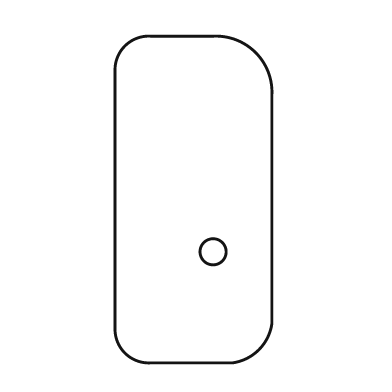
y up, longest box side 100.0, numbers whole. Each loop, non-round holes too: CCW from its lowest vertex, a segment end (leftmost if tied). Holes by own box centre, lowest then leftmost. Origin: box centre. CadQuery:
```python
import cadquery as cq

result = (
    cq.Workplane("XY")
    .moveTo(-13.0, -50.0)
    .lineTo(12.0, -50.0)
    .threePointArc((20.0, -46.0), (24.0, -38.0))
    .lineTo(24.0, 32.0)
    .threePointArc((19.0, 45.0), (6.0, 50.0))
    .lineTo(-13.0, 50.0)
    .threePointArc((-21.0, 47.0), (-24.0, 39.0))
    .lineTo(-24.0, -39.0)
    .threePointArc((-21.0, -47.0), (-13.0, -50.0))
    .close()
    .moveTo(6.0, -16.0)
    .circle(4.0)
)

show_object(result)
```